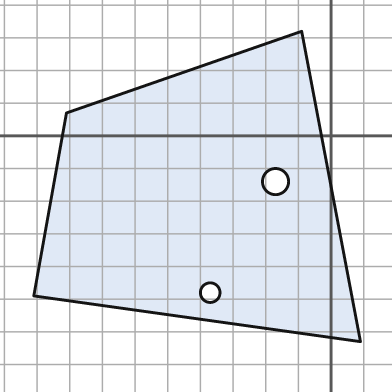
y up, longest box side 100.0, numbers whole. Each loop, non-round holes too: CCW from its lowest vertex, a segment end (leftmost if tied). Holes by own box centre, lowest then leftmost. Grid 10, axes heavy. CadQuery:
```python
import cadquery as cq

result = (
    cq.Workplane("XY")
    .moveTo(9.0, -63.0)
    .lineTo(-9.0, 32.0)
    .lineTo(-81.0, 7.0)
    .lineTo(-91.0, -49.0)
    .close()
    .moveTo(-37.0, -48.0)
    .circle(3.0)
    .moveTo(-17.0, -14.0)
    .circle(4.0)
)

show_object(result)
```